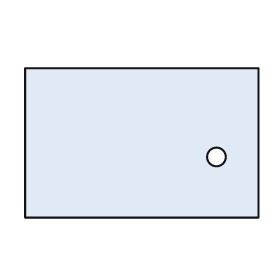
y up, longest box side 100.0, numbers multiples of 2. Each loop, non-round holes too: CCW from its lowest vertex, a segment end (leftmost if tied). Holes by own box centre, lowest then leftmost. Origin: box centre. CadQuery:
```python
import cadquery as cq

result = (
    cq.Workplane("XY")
    .moveTo(-50.0, -32.0)
    .lineTo(50.0, -32.0)
    .lineTo(50.0, 32.0)
    .lineTo(-50.0, 32.0)
    .close()
    .moveTo(32.0, -6.0)
    .circle(4.0)
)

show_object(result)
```